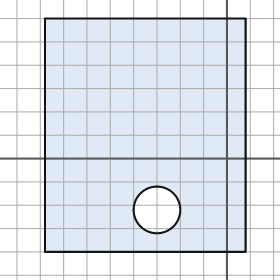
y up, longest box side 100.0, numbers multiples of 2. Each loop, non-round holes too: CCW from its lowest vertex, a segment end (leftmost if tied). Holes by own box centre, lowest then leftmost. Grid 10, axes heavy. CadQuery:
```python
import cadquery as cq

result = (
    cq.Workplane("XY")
    .moveTo(-78.0, -40.0)
    .lineTo(8.0, -40.0)
    .lineTo(8.0, 60.0)
    .lineTo(-78.0, 60.0)
    .close()
    .moveTo(-30.0, -22.0)
    .circle(10.0)
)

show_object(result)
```